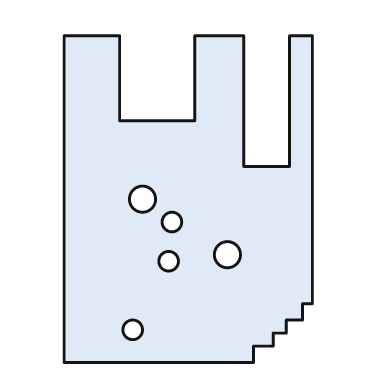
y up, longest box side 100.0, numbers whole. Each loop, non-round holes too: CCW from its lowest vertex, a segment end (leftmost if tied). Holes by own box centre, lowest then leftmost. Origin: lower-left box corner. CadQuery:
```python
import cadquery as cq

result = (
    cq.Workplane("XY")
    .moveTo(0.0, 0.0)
    .lineTo(58.0, 0.0)
    .lineTo(58.0, 5.0)
    .lineTo(64.0, 5.0)
    .lineTo(64.0, 9.0)
    .lineTo(68.0, 9.0)
    .lineTo(68.0, 13.0)
    .lineTo(73.0, 13.0)
    .lineTo(73.0, 18.0)
    .lineTo(76.0, 18.0)
    .lineTo(76.0, 100.0)
    .lineTo(69.0, 100.0)
    .lineTo(69.0, 60.0)
    .lineTo(55.0, 60.0)
    .lineTo(55.0, 100.0)
    .lineTo(40.0, 100.0)
    .lineTo(40.0, 74.0)
    .lineTo(17.0, 74.0)
    .lineTo(17.0, 100.0)
    .lineTo(0.0, 100.0)
    .close()
    .moveTo(21.0, 10.0)
    .circle(3.0)
    .moveTo(32.0, 31.0)
    .circle(3.0)
    .moveTo(50.0, 33.0)
    .circle(4.0)
    .moveTo(33.0, 43.0)
    .circle(3.0)
    .moveTo(24.0, 50.0)
    .circle(4.0)
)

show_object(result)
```